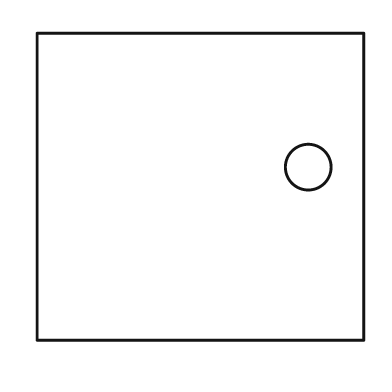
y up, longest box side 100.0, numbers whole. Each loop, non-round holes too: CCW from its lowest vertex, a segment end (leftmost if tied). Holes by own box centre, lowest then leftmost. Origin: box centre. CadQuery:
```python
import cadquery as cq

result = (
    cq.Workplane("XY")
    .moveTo(-50.0, -47.0)
    .lineTo(50.0, -47.0)
    .lineTo(50.0, 47.0)
    .lineTo(-50.0, 47.0)
    .close()
    .moveTo(33.0, 6.0)
    .circle(7.0)
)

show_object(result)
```